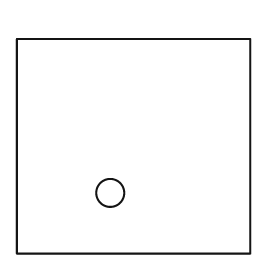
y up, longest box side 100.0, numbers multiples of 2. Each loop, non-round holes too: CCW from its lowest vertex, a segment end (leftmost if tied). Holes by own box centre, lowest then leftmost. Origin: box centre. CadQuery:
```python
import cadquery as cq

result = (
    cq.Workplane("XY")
    .moveTo(-50.0, -46.0)
    .lineTo(50.0, -46.0)
    .lineTo(50.0, 46.0)
    .lineTo(-50.0, 46.0)
    .close()
    .moveTo(-10.0, -20.0)
    .circle(6.0)
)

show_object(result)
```